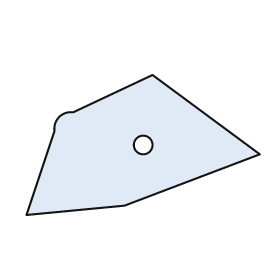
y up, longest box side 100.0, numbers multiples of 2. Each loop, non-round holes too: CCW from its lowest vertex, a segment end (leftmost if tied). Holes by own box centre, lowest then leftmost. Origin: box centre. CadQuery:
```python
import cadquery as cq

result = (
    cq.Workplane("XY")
    .moveTo(-50.0, -30.0)
    .lineTo(-8.0, -26.0)
    .lineTo(50.0, -4.0)
    .lineTo(4.0, 30.0)
    .lineTo(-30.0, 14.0)
    .threePointArc((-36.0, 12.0), (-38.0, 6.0))
    .close()
    .moveTo(0.0, 0.0)
    .circle(4.0)
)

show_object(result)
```